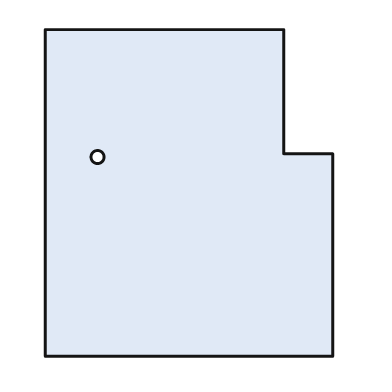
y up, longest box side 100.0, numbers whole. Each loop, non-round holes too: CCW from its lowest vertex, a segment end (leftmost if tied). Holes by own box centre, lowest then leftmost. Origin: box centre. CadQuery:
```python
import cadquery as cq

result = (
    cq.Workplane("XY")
    .moveTo(-44.0, -50.0)
    .lineTo(44.0, -50.0)
    .lineTo(44.0, 12.0)
    .lineTo(29.0, 12.0)
    .lineTo(29.0, 50.0)
    .lineTo(-44.0, 50.0)
    .close()
    .moveTo(-28.0, 11.0)
    .circle(2.0)
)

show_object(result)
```